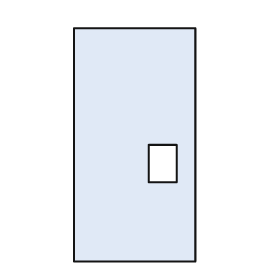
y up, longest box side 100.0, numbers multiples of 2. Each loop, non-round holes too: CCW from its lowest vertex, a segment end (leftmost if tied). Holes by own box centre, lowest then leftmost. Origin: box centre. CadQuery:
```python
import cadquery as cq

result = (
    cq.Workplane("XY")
    .moveTo(-26.0, -50.0)
    .lineTo(26.0, -50.0)
    .lineTo(26.0, 50.0)
    .lineTo(-26.0, 50.0)
    .close()
    .moveTo(6.0, -16.0)
    .lineTo(18.0, -16.0)
    .lineTo(18.0, 0.0)
    .lineTo(6.0, 0.0)
    .close()
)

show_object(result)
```